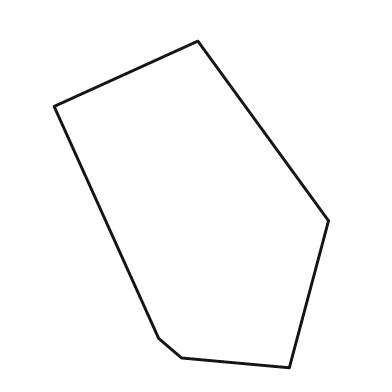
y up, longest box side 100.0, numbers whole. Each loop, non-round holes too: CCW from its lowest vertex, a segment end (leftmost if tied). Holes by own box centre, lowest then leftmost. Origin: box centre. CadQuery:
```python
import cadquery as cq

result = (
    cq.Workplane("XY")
    .moveTo(30.0, -50.0)
    .lineTo(42.0, -5.0)
    .lineTo(2.0, 50.0)
    .lineTo(-42.0, 30.0)
    .lineTo(-10.0, -41.0)
    .lineTo(-3.0, -47.0)
    .close()
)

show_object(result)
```